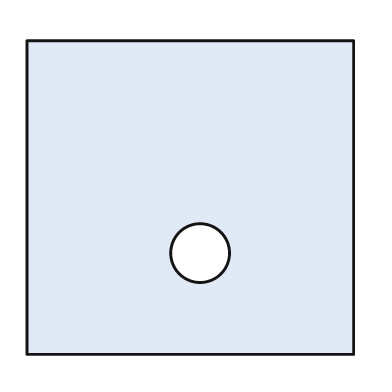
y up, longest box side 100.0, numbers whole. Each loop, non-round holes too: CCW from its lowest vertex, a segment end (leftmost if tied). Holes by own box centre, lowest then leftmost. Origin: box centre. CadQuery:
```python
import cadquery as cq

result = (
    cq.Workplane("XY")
    .moveTo(-50.0, -48.0)
    .lineTo(50.0, -48.0)
    .lineTo(50.0, 48.0)
    .lineTo(-50.0, 48.0)
    .close()
    .moveTo(3.0, -17.0)
    .circle(9.0)
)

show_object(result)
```